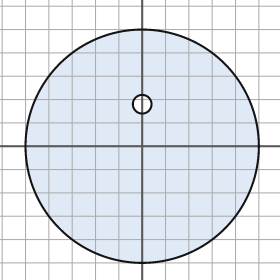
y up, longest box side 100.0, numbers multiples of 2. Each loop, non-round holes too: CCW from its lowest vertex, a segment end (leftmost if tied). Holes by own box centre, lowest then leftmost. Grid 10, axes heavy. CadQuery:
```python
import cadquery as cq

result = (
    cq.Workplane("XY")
    .moveTo(0.0, 0.0)
    .circle(50.0)
    .moveTo(0.0, 18.0)
    .circle(4.0)
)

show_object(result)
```